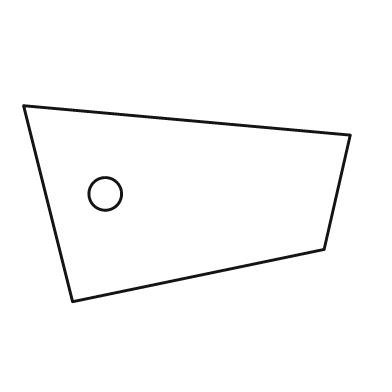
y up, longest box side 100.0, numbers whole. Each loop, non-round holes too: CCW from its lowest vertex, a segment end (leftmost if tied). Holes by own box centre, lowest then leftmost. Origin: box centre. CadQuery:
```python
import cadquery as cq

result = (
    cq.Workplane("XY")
    .moveTo(-35.0, -30.0)
    .lineTo(42.0, -14.0)
    .lineTo(50.0, 21.0)
    .lineTo(-50.0, 30.0)
    .close()
    .moveTo(-25.0, 3.0)
    .circle(5.0)
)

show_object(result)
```